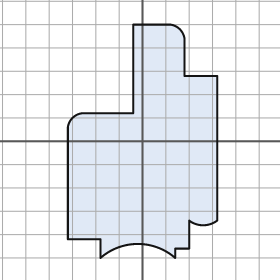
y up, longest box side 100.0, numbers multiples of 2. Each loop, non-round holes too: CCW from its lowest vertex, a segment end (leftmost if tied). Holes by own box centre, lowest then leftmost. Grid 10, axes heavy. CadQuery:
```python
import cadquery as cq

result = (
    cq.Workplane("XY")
    .moveTo(-18.0, -50.0)
    .threePointArc((-2.0, -44.0), (14.0, -50.0))
    .lineTo(14.0, -46.0)
    .lineTo(20.0, -46.0)
    .lineTo(20.0, -34.0)
    .threePointArc((26.0, -36.0), (32.0, -34.0))
    .lineTo(32.0, 28.0)
    .lineTo(18.0, 28.0)
    .lineTo(18.0, 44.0)
    .threePointArc((16.0, 48.0), (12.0, 50.0))
    .lineTo(-4.0, 50.0)
    .lineTo(-4.0, 12.0)
    .lineTo(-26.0, 12.0)
    .threePointArc((-30.0, 10.0), (-32.0, 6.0))
    .lineTo(-32.0, -42.0)
    .lineTo(-18.0, -42.0)
    .close()
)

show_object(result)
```